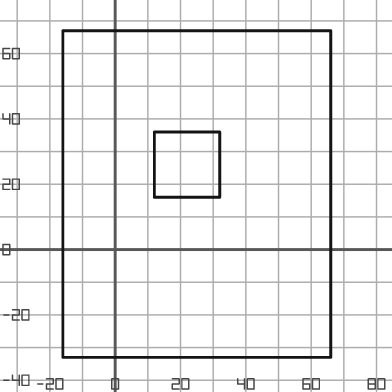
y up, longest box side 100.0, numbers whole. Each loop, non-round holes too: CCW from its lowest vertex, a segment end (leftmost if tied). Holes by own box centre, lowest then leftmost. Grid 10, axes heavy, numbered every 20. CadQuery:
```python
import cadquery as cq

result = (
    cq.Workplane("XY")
    .moveTo(-16.0, -33.0)
    .lineTo(66.0, -33.0)
    .lineTo(66.0, 67.0)
    .lineTo(-16.0, 67.0)
    .close()
    .moveTo(12.0, 16.0)
    .lineTo(32.0, 16.0)
    .lineTo(32.0, 36.0)
    .lineTo(12.0, 36.0)
    .close()
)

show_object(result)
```